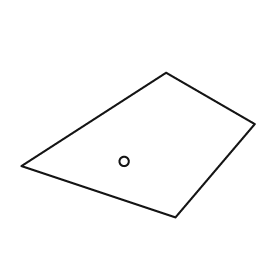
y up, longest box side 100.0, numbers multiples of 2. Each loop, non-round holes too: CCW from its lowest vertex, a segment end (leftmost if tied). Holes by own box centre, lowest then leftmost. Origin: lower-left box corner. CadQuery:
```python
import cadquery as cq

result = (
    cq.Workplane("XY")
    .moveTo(66.0, 0.0)
    .lineTo(100.0, 40.0)
    .lineTo(62.0, 62.0)
    .lineTo(0.0, 22.0)
    .close()
    .moveTo(44.0, 24.0)
    .circle(2.0)
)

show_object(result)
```